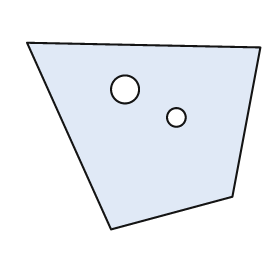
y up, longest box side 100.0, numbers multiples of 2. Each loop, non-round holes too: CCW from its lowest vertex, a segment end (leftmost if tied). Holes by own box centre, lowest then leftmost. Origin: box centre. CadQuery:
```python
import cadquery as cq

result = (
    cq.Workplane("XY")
    .moveTo(-14.0, -40.0)
    .lineTo(38.0, -26.0)
    .lineTo(50.0, 38.0)
    .lineTo(-50.0, 40.0)
    .close()
    .moveTo(14.0, 8.0)
    .circle(4.0)
    .moveTo(-8.0, 20.0)
    .circle(6.0)
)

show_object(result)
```